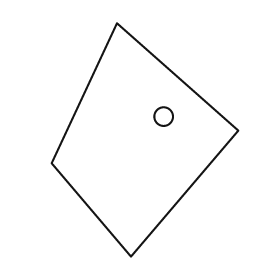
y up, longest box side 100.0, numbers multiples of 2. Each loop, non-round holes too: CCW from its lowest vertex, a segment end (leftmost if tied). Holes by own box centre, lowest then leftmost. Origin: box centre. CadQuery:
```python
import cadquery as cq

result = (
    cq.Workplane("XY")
    .moveTo(-6.0, -50.0)
    .lineTo(40.0, 4.0)
    .lineTo(-12.0, 50.0)
    .lineTo(-40.0, -10.0)
    .close()
    .moveTo(8.0, 10.0)
    .circle(4.0)
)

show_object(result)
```